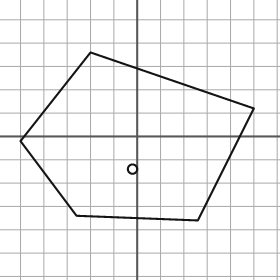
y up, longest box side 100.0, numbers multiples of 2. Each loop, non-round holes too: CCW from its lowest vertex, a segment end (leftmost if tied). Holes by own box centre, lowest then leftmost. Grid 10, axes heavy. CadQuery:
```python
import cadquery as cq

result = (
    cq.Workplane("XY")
    .moveTo(26.0, -36.0)
    .lineTo(50.0, 12.0)
    .lineTo(-20.0, 36.0)
    .lineTo(-50.0, -2.0)
    .lineTo(-26.0, -34.0)
    .close()
    .moveTo(-2.0, -14.0)
    .circle(2.0)
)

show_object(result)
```